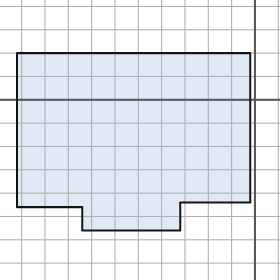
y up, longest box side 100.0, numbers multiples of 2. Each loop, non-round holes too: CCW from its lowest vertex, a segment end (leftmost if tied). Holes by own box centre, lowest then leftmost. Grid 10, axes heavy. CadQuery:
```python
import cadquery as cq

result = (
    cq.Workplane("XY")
    .moveTo(-74.0, -56.0)
    .lineTo(-32.0, -56.0)
    .lineTo(-32.0, -44.0)
    .lineTo(-2.0, -44.0)
    .lineTo(-2.0, 20.0)
    .lineTo(-102.0, 20.0)
    .lineTo(-102.0, -46.0)
    .lineTo(-74.0, -46.0)
    .close()
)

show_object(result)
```